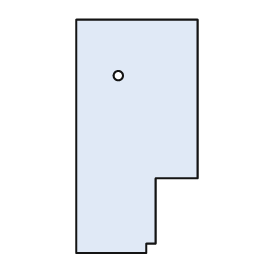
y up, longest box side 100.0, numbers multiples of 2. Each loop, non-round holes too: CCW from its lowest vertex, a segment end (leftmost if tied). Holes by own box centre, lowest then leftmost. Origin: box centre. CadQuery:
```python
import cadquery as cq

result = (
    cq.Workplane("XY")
    .moveTo(-26.0, -50.0)
    .lineTo(4.0, -50.0)
    .lineTo(4.0, -46.0)
    .lineTo(8.0, -46.0)
    .lineTo(8.0, -18.0)
    .lineTo(26.0, -18.0)
    .lineTo(26.0, 50.0)
    .lineTo(-26.0, 50.0)
    .close()
    .moveTo(-8.0, 26.0)
    .circle(2.0)
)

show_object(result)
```